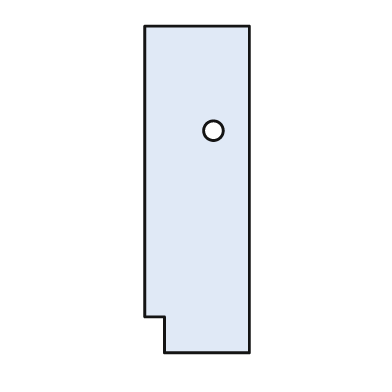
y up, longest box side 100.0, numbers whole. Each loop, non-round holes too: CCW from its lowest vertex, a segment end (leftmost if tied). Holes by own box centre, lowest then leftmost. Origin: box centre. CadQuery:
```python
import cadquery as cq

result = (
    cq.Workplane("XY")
    .moveTo(-10.0, -50.0)
    .lineTo(16.0, -50.0)
    .lineTo(16.0, 50.0)
    .lineTo(-16.0, 50.0)
    .lineTo(-16.0, -39.0)
    .lineTo(-10.0, -39.0)
    .close()
    .moveTo(5.0, 18.0)
    .circle(3.0)
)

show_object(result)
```